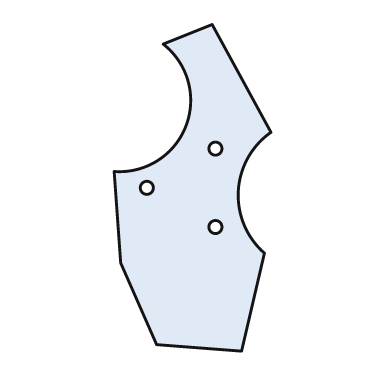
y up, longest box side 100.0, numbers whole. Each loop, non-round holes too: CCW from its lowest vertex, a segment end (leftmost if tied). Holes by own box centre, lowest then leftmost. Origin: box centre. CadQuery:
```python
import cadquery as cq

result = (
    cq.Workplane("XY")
    .moveTo(15.0, -50.0)
    .lineTo(22.0, -20.0)
    .threePointArc((14.0, -1.0), (24.0, 17.0))
    .lineTo(6.0, 50.0)
    .lineTo(-9.0, 44.0)
    .threePointArc((-2.0, 19.0), (-24.0, 5.0))
    .lineTo(-22.0, -23.0)
    .lineTo(-11.0, -48.0)
    .close()
    .moveTo(7.0, -12.0)
    .circle(2.0)
    .moveTo(-14.0, 0.0)
    .circle(2.0)
    .moveTo(7.0, 12.0)
    .circle(2.0)
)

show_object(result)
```